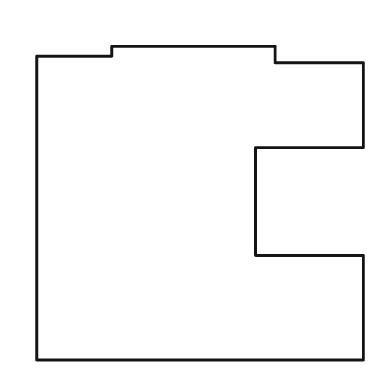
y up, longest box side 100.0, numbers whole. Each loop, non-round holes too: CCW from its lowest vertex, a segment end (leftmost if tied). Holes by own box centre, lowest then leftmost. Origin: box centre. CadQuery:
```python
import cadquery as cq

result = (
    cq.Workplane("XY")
    .moveTo(-50.0, -48.0)
    .lineTo(50.0, -48.0)
    .lineTo(50.0, -16.0)
    .lineTo(17.0, -16.0)
    .lineTo(17.0, 17.0)
    .lineTo(50.0, 17.0)
    .lineTo(50.0, 43.0)
    .lineTo(23.0, 43.0)
    .lineTo(23.0, 48.0)
    .lineTo(-27.0, 48.0)
    .lineTo(-27.0, 45.0)
    .lineTo(-50.0, 45.0)
    .close()
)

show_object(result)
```